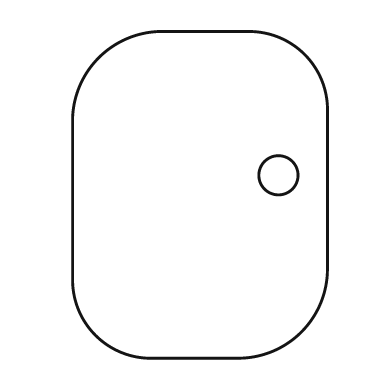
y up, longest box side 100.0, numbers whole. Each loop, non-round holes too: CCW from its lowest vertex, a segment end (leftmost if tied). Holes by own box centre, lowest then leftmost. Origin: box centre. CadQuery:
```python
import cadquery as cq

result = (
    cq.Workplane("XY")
    .moveTo(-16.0, -50.0)
    .lineTo(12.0, -50.0)
    .threePointArc((31.0, -42.0), (39.0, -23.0))
    .lineTo(39.0, 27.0)
    .threePointArc((32.0, 43.0), (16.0, 50.0))
    .lineTo(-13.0, 50.0)
    .threePointArc((-31.0, 42.0), (-39.0, 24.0))
    .lineTo(-39.0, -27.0)
    .threePointArc((-32.0, -43.0), (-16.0, -50.0))
    .close()
    .moveTo(24.0, 6.0)
    .circle(6.0)
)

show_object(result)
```